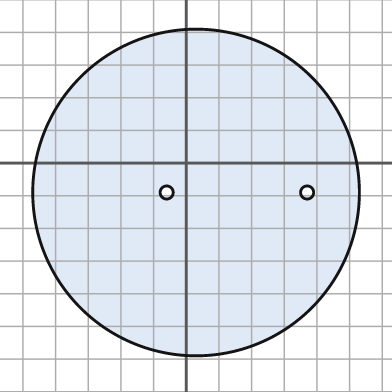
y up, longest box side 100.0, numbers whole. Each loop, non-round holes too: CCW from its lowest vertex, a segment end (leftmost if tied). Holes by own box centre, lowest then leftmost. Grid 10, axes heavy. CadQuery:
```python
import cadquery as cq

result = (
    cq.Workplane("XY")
    .moveTo(3.0, -9.0)
    .circle(50.0)
    .moveTo(-6.0, -9.0)
    .circle(2.0)
    .moveTo(37.0, -9.0)
    .circle(2.0)
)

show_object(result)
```